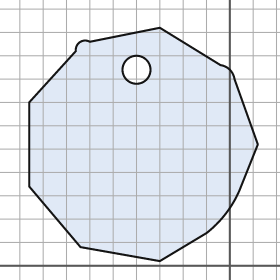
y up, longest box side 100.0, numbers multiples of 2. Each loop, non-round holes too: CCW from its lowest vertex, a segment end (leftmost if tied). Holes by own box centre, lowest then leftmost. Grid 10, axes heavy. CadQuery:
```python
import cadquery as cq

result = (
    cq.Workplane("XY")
    .moveTo(-30.0, 2.0)
    .lineTo(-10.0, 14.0)
    .threePointArc((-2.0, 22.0), (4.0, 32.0))
    .lineTo(12.0, 52.0)
    .lineTo(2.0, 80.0)
    .threePointArc((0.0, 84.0), (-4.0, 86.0))
    .lineTo(-30.0, 102.0)
    .lineTo(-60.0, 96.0)
    .threePointArc((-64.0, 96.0), (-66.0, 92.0))
    .lineTo(-86.0, 70.0)
    .lineTo(-86.0, 34.0)
    .lineTo(-64.0, 8.0)
    .close()
    .moveTo(-40.0, 84.0)
    .circle(6.0)
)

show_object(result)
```